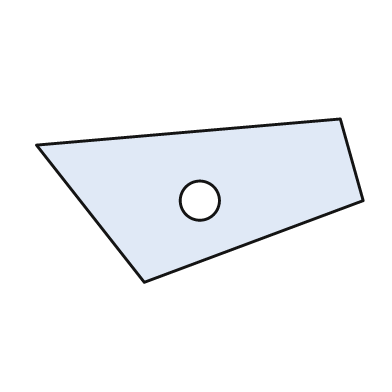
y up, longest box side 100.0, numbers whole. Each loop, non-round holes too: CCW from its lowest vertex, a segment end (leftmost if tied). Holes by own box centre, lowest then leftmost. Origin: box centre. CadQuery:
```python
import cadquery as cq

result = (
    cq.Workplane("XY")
    .moveTo(-17.0, -25.0)
    .lineTo(50.0, 0.0)
    .lineTo(43.0, 25.0)
    .lineTo(-50.0, 17.0)
    .close()
    .moveTo(0.0, 0.0)
    .circle(6.0)
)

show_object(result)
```